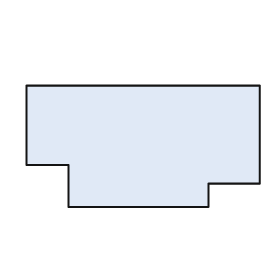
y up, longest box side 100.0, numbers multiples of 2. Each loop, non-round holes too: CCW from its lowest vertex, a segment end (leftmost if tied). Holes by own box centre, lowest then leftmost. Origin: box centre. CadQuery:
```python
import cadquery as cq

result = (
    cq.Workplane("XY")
    .moveTo(-32.0, -26.0)
    .lineTo(28.0, -26.0)
    .lineTo(28.0, -16.0)
    .lineTo(50.0, -16.0)
    .lineTo(50.0, 26.0)
    .lineTo(-50.0, 26.0)
    .lineTo(-50.0, -8.0)
    .lineTo(-32.0, -8.0)
    .close()
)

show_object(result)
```